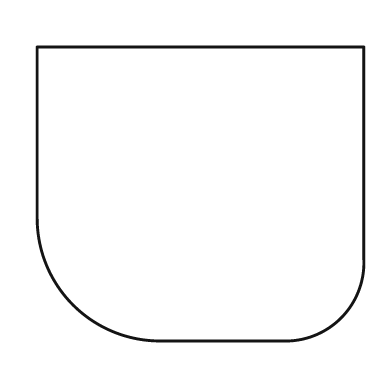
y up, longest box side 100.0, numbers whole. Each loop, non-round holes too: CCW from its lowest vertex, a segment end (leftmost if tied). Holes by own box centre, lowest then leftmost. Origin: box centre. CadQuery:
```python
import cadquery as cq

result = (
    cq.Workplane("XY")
    .moveTo(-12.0, -45.0)
    .lineTo(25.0, -45.0)
    .threePointArc((43.0, -38.0), (50.0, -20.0))
    .lineTo(50.0, 45.0)
    .lineTo(-50.0, 45.0)
    .lineTo(-50.0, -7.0)
    .threePointArc((-39.0, -34.0), (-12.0, -45.0))
    .close()
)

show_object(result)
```